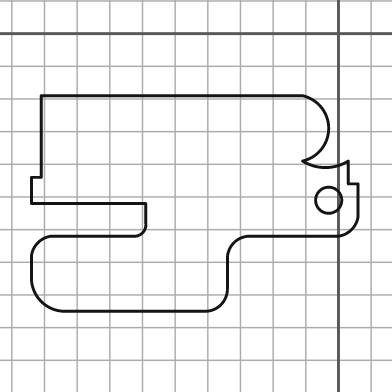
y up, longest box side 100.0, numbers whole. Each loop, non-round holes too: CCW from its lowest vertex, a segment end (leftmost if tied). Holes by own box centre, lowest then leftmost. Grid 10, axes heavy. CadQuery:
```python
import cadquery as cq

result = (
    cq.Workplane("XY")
    .moveTo(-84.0, -85.0)
    .lineTo(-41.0, -85.0)
    .threePointArc((-36.0, -83.0), (-34.0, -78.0))
    .lineTo(-34.0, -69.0)
    .threePointArc((-32.0, -64.0), (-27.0, -62.0))
    .lineTo(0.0, -62.0)
    .threePointArc((4.0, -60.0), (6.0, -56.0))
    .lineTo(6.0, -46.0)
    .lineTo(3.0, -46.0)
    .lineTo(3.0, -39.0)
    .threePointArc((-4.0, -41.0), (-11.0, -39.0))
    .threePointArc((-3.0, -29.0), (-11.0, -19.0))
    .lineTo(-91.0, -19.0)
    .lineTo(-91.0, -44.0)
    .lineTo(-94.0, -44.0)
    .lineTo(-94.0, -52.0)
    .lineTo(-59.0, -52.0)
    .lineTo(-59.0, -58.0)
    .threePointArc((-60.0, -61.0), (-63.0, -62.0))
    .lineTo(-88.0, -62.0)
    .threePointArc((-92.0, -64.0), (-94.0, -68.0))
    .lineTo(-94.0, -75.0)
    .threePointArc((-91.0, -82.0), (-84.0, -85.0))
    .close()
    .moveTo(-3.0, -51.0)
    .circle(4.0)
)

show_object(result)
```